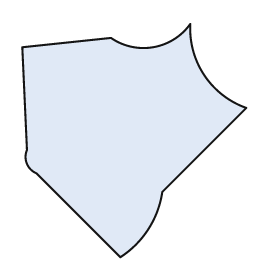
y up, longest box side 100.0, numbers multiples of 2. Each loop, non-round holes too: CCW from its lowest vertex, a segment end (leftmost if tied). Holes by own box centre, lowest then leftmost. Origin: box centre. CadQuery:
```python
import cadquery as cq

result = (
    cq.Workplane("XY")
    .moveTo(-6.0, -50.0)
    .threePointArc((6.0, -38.0), (12.0, -22.0))
    .lineTo(48.0, 14.0)
    .threePointArc((30.0, 28.0), (24.0, 50.0))
    .threePointArc((8.0, 40.0), (-10.0, 44.0))
    .lineTo(-48.0, 40.0)
    .lineTo(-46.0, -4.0)
    .threePointArc((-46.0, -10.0), (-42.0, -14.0))
    .close()
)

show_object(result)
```